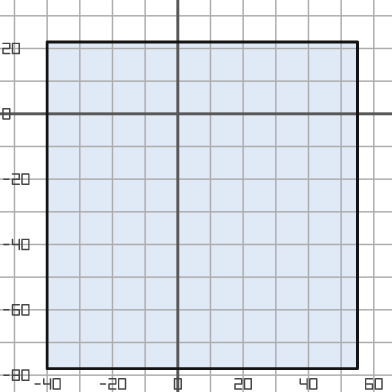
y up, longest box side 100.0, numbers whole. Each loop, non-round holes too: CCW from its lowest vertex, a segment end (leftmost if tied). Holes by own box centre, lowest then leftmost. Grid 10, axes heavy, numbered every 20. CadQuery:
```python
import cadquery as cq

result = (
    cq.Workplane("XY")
    .moveTo(-40.0, -78.0)
    .lineTo(55.0, -78.0)
    .lineTo(55.0, 22.0)
    .lineTo(-40.0, 22.0)
    .close()
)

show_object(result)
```